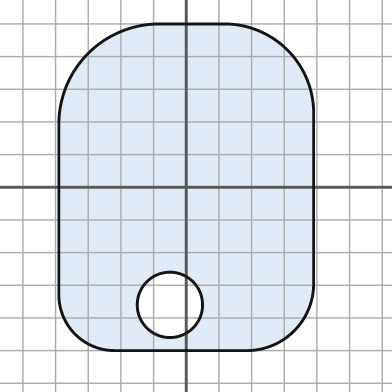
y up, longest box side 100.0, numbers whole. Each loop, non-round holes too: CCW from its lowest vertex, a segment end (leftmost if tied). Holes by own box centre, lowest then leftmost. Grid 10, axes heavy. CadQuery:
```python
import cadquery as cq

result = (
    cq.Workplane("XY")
    .moveTo(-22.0, -50.0)
    .lineTo(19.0, -50.0)
    .threePointArc((33.0, -44.0), (39.0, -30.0))
    .lineTo(39.0, 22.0)
    .threePointArc((31.0, 42.0), (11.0, 50.0))
    .lineTo(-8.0, 50.0)
    .threePointArc((-30.0, 41.0), (-39.0, 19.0))
    .lineTo(-39.0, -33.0)
    .threePointArc((-34.0, -45.0), (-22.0, -50.0))
    .close()
    .moveTo(-5.0, -36.0)
    .circle(10.0)
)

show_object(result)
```